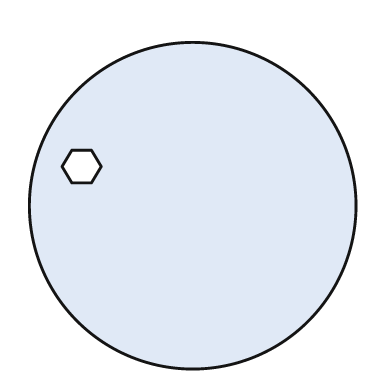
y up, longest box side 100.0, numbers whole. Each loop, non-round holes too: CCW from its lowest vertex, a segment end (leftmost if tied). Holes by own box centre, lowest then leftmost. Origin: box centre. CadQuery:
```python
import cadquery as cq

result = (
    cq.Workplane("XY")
    .moveTo(0.0, 0.0)
    .circle(50.0)
    .moveTo(-37.0, 7.0)
    .lineTo(-31.0, 7.0)
    .lineTo(-28.0, 12.0)
    .lineTo(-31.0, 17.0)
    .lineTo(-37.0, 17.0)
    .lineTo(-40.0, 12.0)
    .close()
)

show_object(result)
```